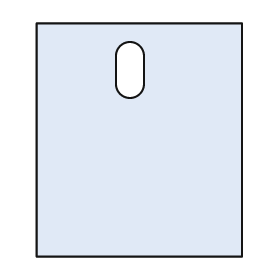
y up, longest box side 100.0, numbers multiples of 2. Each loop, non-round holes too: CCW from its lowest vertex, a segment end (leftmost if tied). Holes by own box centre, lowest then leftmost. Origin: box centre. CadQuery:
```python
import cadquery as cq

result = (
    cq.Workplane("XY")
    .moveTo(-44.0, -50.0)
    .lineTo(44.0, -50.0)
    .lineTo(44.0, 50.0)
    .lineTo(-44.0, 50.0)
    .close()
    .moveTo(-10.0, 24.0)
    .threePointArc((-4.0, 18.0), (2.0, 24.0))
    .lineTo(2.0, 36.0)
    .threePointArc((-4.0, 42.0), (-10.0, 36.0))
    .close()
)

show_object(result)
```